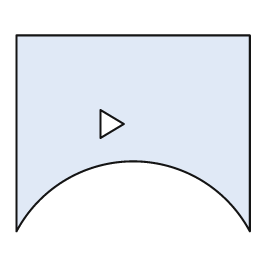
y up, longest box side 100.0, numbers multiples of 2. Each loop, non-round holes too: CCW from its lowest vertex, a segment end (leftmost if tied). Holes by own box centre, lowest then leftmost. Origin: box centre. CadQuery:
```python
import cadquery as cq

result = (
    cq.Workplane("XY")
    .moveTo(-50.0, -42.0)
    .threePointArc((0.0, -12.0), (50.0, -42.0))
    .lineTo(50.0, 42.0)
    .lineTo(-50.0, 42.0)
    .close()
    .moveTo(-14.0, -2.0)
    .lineTo(-4.0, 4.0)
    .lineTo(-14.0, 10.0)
    .close()
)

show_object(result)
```